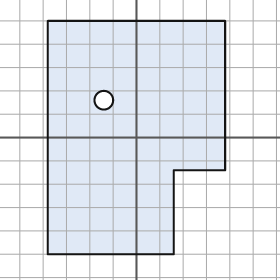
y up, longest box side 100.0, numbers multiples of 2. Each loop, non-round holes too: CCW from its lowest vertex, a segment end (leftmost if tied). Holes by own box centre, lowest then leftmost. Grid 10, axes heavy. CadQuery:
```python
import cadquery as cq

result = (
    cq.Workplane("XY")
    .moveTo(-38.0, -50.0)
    .lineTo(16.0, -50.0)
    .lineTo(16.0, -14.0)
    .lineTo(38.0, -14.0)
    .lineTo(38.0, 50.0)
    .lineTo(-38.0, 50.0)
    .close()
    .moveTo(-14.0, 16.0)
    .circle(4.0)
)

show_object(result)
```